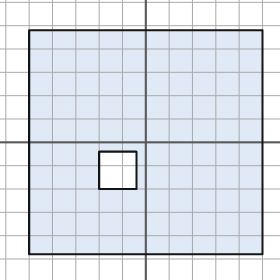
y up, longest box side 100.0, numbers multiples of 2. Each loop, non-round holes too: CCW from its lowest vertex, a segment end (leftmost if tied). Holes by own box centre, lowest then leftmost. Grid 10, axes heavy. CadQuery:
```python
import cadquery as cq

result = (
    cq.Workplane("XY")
    .moveTo(-50.0, -48.0)
    .lineTo(50.0, -48.0)
    .lineTo(50.0, 48.0)
    .lineTo(-50.0, 48.0)
    .close()
    .moveTo(-20.0, -20.0)
    .lineTo(-4.0, -20.0)
    .lineTo(-4.0, -4.0)
    .lineTo(-20.0, -4.0)
    .close()
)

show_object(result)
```